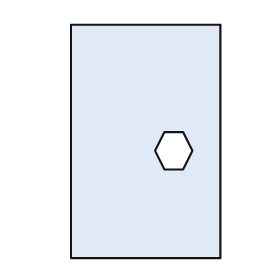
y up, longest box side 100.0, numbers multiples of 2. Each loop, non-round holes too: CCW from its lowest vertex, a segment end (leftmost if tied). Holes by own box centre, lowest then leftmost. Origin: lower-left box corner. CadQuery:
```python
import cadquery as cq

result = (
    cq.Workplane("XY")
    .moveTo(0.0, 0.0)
    .lineTo(64.0, 0.0)
    .lineTo(64.0, 100.0)
    .lineTo(0.0, 100.0)
    .close()
    .moveTo(40.0, 38.0)
    .lineTo(48.0, 38.0)
    .lineTo(52.0, 46.0)
    .lineTo(48.0, 54.0)
    .lineTo(40.0, 54.0)
    .lineTo(36.0, 46.0)
    .close()
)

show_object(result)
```